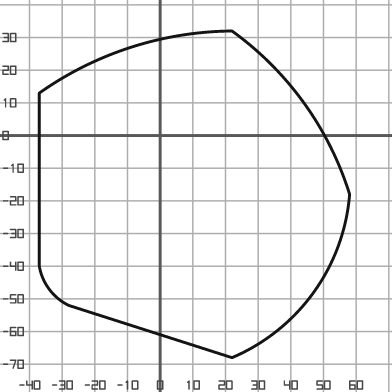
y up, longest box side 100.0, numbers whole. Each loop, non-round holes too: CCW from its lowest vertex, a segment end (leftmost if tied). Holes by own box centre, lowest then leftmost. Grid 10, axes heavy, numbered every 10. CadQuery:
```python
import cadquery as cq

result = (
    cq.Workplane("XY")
    .moveTo(22.0, -68.0)
    .threePointArc((47.0, -48.0), (58.0, -18.0))
    .threePointArc((44.0, 10.0), (22.0, 32.0))
    .threePointArc((-9.0, 27.0), (-37.0, 13.0))
    .lineTo(-37.0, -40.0)
    .threePointArc((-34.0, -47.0), (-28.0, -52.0))
    .close()
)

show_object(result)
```